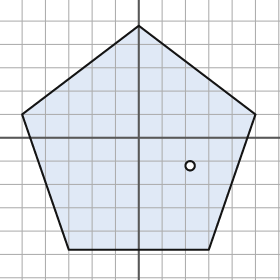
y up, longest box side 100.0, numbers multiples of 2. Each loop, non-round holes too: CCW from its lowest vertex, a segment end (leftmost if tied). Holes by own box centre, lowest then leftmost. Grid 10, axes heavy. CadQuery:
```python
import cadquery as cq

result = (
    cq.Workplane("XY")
    .moveTo(-30.0, -48.0)
    .lineTo(30.0, -48.0)
    .lineTo(50.0, 10.0)
    .lineTo(0.0, 48.0)
    .lineTo(-50.0, 10.0)
    .close()
    .moveTo(22.0, -12.0)
    .circle(2.0)
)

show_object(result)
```